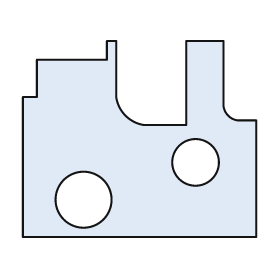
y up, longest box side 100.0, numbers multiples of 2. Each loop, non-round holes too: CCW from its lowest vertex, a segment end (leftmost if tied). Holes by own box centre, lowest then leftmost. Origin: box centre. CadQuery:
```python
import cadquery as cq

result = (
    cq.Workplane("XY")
    .moveTo(-50.0, -42.0)
    .lineTo(50.0, -42.0)
    .lineTo(50.0, 8.0)
    .lineTo(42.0, 8.0)
    .threePointArc((38.0, 10.0), (36.0, 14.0))
    .lineTo(36.0, 42.0)
    .lineTo(20.0, 42.0)
    .lineTo(20.0, 6.0)
    .lineTo(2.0, 6.0)
    .threePointArc((-6.0, 10.0), (-10.0, 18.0))
    .lineTo(-10.0, 42.0)
    .lineTo(-14.0, 42.0)
    .lineTo(-14.0, 34.0)
    .lineTo(-44.0, 34.0)
    .lineTo(-44.0, 18.0)
    .lineTo(-50.0, 18.0)
    .close()
    .moveTo(-24.0, -26.0)
    .circle(12.0)
    .moveTo(24.0, -10.0)
    .circle(10.0)
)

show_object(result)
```